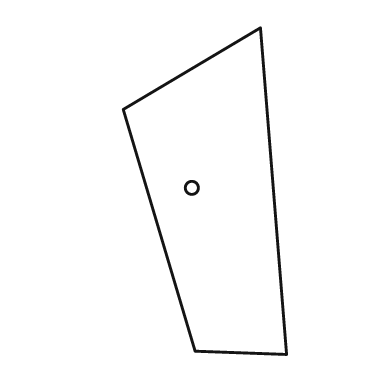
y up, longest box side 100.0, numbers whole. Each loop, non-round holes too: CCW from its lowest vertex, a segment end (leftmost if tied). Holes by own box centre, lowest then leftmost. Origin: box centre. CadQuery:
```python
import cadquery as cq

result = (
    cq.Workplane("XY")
    .moveTo(25.0, -50.0)
    .lineTo(17.0, 50.0)
    .lineTo(-25.0, 25.0)
    .lineTo(-3.0, -49.0)
    .close()
    .moveTo(-4.0, 1.0)
    .circle(2.0)
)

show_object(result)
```